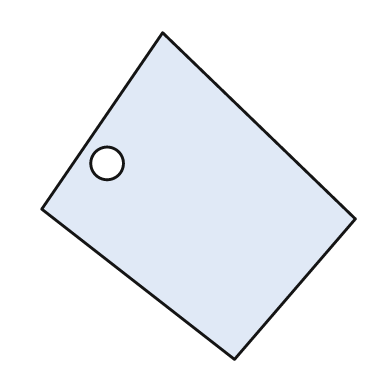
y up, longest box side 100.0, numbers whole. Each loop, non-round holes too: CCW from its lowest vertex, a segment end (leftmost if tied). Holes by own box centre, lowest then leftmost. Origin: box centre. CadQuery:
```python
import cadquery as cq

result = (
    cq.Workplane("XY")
    .moveTo(11.0, -50.0)
    .lineTo(48.0, -7.0)
    .lineTo(-11.0, 50.0)
    .lineTo(-48.0, -4.0)
    .close()
    .moveTo(-28.0, 10.0)
    .circle(5.0)
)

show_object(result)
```